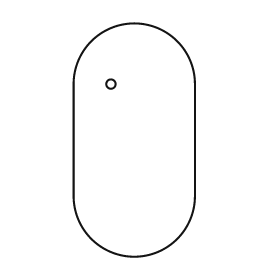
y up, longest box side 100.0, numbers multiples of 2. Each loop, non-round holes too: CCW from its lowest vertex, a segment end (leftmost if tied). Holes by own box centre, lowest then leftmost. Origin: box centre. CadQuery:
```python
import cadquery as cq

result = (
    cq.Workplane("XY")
    .moveTo(-26.0, -24.0)
    .threePointArc((0.0, -50.0), (26.0, -24.0))
    .lineTo(26.0, 24.0)
    .threePointArc((0.0, 50.0), (-26.0, 24.0))
    .close()
    .moveTo(-10.0, 24.0)
    .circle(2.0)
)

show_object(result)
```